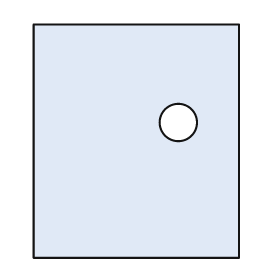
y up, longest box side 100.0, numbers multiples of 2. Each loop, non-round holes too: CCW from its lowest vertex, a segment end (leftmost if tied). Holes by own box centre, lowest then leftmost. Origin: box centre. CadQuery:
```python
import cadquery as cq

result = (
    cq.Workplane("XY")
    .moveTo(-44.0, -50.0)
    .lineTo(44.0, -50.0)
    .lineTo(44.0, 50.0)
    .lineTo(-44.0, 50.0)
    .close()
    .moveTo(18.0, 8.0)
    .circle(8.0)
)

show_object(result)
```